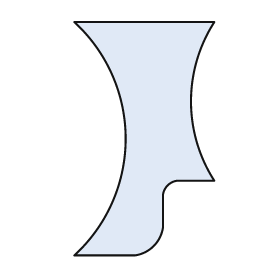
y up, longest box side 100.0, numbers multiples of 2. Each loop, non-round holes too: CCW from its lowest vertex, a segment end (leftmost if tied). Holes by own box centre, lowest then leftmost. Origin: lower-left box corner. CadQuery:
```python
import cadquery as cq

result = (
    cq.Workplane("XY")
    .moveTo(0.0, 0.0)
    .lineTo(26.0, 0.0)
    .threePointArc((34.0, 4.0), (38.0, 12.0))
    .lineTo(38.0, 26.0)
    .threePointArc((40.0, 30.0), (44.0, 32.0))
    .lineTo(60.0, 32.0)
    .threePointArc((50.0, 66.0), (60.0, 100.0))
    .lineTo(0.0, 100.0)
    .threePointArc((22.0, 50.0), (0.0, 0.0))
    .close()
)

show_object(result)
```